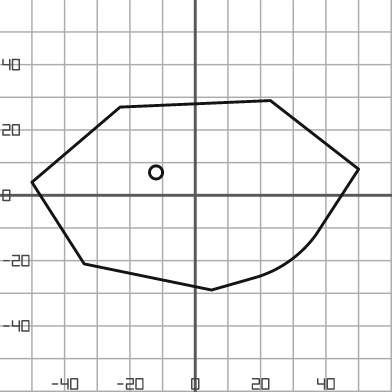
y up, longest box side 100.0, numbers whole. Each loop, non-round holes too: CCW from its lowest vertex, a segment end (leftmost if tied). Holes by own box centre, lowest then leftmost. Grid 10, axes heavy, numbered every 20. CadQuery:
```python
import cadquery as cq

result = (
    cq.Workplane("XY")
    .moveTo(5.0, -29.0)
    .lineTo(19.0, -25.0)
    .threePointArc((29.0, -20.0), (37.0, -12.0))
    .lineTo(50.0, 8.0)
    .lineTo(23.0, 29.0)
    .lineTo(-23.0, 27.0)
    .lineTo(-50.0, 4.0)
    .lineTo(-34.0, -21.0)
    .close()
    .moveTo(-12.0, 7.0)
    .circle(2.0)
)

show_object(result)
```